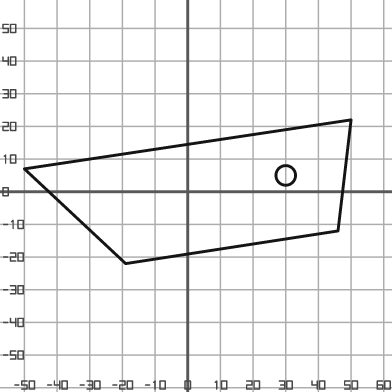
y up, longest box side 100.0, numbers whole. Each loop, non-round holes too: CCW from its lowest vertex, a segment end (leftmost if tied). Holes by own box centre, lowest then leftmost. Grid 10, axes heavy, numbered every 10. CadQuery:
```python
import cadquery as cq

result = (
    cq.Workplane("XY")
    .moveTo(-19.0, -22.0)
    .lineTo(46.0, -12.0)
    .lineTo(50.0, 22.0)
    .lineTo(-50.0, 7.0)
    .close()
    .moveTo(30.0, 5.0)
    .circle(3.0)
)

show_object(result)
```